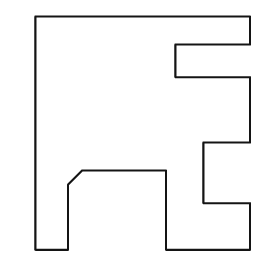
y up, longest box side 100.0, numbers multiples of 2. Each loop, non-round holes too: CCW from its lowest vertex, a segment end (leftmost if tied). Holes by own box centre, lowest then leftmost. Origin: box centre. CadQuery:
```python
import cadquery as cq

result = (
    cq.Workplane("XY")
    .moveTo(-46.0, -50.0)
    .lineTo(-32.0, -50.0)
    .lineTo(-32.0, -22.0)
    .lineTo(-26.0, -16.0)
    .lineTo(10.0, -16.0)
    .lineTo(10.0, -50.0)
    .lineTo(46.0, -50.0)
    .lineTo(46.0, -30.0)
    .lineTo(26.0, -30.0)
    .lineTo(26.0, -4.0)
    .lineTo(46.0, -4.0)
    .lineTo(46.0, 24.0)
    .lineTo(14.0, 24.0)
    .lineTo(14.0, 38.0)
    .lineTo(46.0, 38.0)
    .lineTo(46.0, 50.0)
    .lineTo(-46.0, 50.0)
    .close()
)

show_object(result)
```